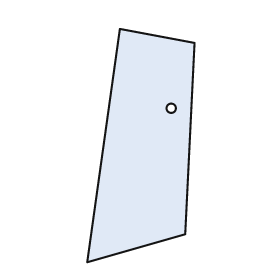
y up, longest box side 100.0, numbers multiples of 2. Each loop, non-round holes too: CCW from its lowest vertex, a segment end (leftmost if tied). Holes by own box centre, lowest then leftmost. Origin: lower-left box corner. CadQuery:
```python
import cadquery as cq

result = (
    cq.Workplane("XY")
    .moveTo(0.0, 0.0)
    .lineTo(42.0, 12.0)
    .lineTo(46.0, 94.0)
    .lineTo(14.0, 100.0)
    .close()
    .moveTo(36.0, 66.0)
    .circle(2.0)
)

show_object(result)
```